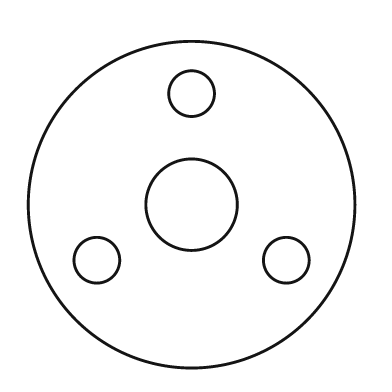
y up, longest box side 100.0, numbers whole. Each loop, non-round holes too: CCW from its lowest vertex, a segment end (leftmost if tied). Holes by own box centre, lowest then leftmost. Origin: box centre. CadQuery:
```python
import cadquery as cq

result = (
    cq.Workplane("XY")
    .moveTo(0.0, 0.0)
    .circle(50.0)
    .moveTo(-29.0, -17.0)
    .circle(7.0)
    .moveTo(29.0, -17.0)
    .circle(7.0)
    .moveTo(0.0, 0.0)
    .circle(14.0)
    .moveTo(0.0, 34.0)
    .circle(7.0)
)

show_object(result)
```